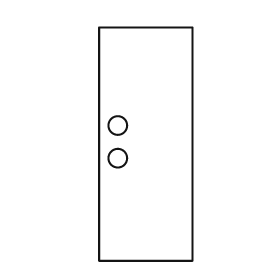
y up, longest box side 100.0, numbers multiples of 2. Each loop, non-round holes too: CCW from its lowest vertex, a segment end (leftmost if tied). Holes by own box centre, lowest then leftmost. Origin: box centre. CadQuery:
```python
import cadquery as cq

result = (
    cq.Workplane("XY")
    .moveTo(-20.0, -50.0)
    .lineTo(20.0, -50.0)
    .lineTo(20.0, 50.0)
    .lineTo(-20.0, 50.0)
    .close()
    .moveTo(-12.0, -6.0)
    .circle(4.0)
    .moveTo(-12.0, 8.0)
    .circle(4.0)
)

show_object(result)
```